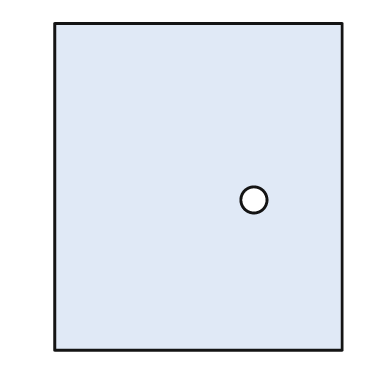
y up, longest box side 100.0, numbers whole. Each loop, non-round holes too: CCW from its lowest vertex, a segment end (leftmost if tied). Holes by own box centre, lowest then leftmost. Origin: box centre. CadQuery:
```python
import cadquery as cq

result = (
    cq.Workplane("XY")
    .moveTo(-44.0, -50.0)
    .lineTo(44.0, -50.0)
    .lineTo(44.0, 50.0)
    .lineTo(-44.0, 50.0)
    .close()
    .moveTo(17.0, -4.0)
    .circle(4.0)
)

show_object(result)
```